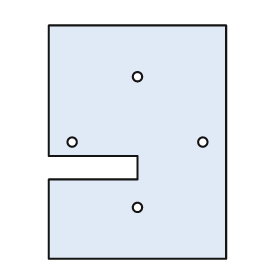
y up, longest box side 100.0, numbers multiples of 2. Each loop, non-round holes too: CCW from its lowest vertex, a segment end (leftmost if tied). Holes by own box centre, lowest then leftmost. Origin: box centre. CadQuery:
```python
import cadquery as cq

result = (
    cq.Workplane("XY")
    .moveTo(-38.0, -50.0)
    .lineTo(38.0, -50.0)
    .lineTo(38.0, 50.0)
    .lineTo(-38.0, 50.0)
    .lineTo(-38.0, -6.0)
    .lineTo(0.0, -6.0)
    .lineTo(0.0, -16.0)
    .lineTo(-38.0, -16.0)
    .close()
    .moveTo(0.0, -28.0)
    .circle(2.0)
    .moveTo(-28.0, 0.0)
    .circle(2.0)
    .moveTo(28.0, 0.0)
    .circle(2.0)
    .moveTo(0.0, 28.0)
    .circle(2.0)
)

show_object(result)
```